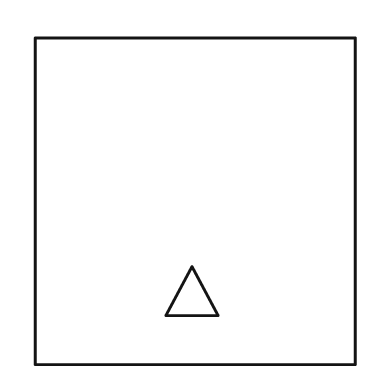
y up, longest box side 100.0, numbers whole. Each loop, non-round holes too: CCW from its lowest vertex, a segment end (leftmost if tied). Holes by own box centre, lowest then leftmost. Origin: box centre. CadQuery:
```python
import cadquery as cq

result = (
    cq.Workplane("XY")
    .moveTo(-49.0, -50.0)
    .lineTo(49.0, -50.0)
    .lineTo(49.0, 50.0)
    .lineTo(-49.0, 50.0)
    .close()
    .moveTo(-9.0, -35.0)
    .lineTo(7.0, -35.0)
    .lineTo(-1.0, -20.0)
    .close()
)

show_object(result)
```